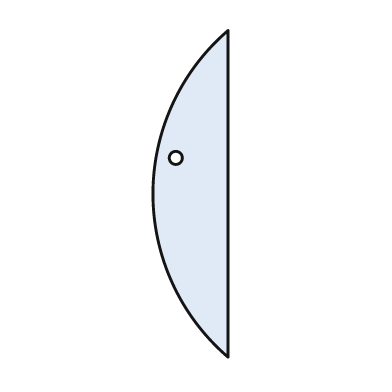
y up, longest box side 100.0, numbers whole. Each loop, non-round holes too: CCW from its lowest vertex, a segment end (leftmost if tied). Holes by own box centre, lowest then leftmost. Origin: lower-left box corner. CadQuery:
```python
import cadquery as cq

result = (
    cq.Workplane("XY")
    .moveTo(23.0, 0.0)
    .lineTo(23.0, 100.0)
    .threePointArc((0.0, 50.0), (23.0, 0.0))
    .close()
    .moveTo(7.0, 61.0)
    .circle(2.0)
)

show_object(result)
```